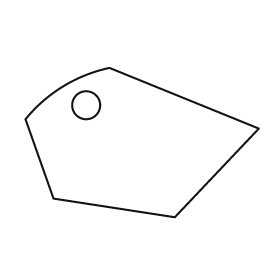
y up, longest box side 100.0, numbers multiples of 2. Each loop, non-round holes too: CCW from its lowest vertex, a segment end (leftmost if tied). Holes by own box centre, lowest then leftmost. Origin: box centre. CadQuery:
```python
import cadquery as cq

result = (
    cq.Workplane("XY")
    .moveTo(14.0, -32.0)
    .lineTo(50.0, 6.0)
    .lineTo(-14.0, 32.0)
    .threePointArc((-34.0, 24.0), (-50.0, 10.0))
    .lineTo(-38.0, -24.0)
    .close()
    .moveTo(-24.0, 16.0)
    .circle(6.0)
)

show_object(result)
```